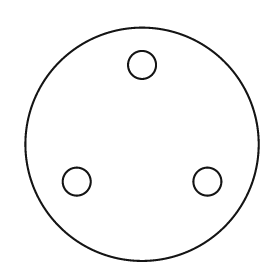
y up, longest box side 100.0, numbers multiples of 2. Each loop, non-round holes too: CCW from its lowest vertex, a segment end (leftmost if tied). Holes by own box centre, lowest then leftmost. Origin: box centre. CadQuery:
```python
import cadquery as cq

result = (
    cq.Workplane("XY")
    .moveTo(0.0, 0.0)
    .circle(50.0)
    .moveTo(-28.0, -16.0)
    .circle(6.0)
    .moveTo(28.0, -16.0)
    .circle(6.0)
    .moveTo(0.0, 34.0)
    .circle(6.0)
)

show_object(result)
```